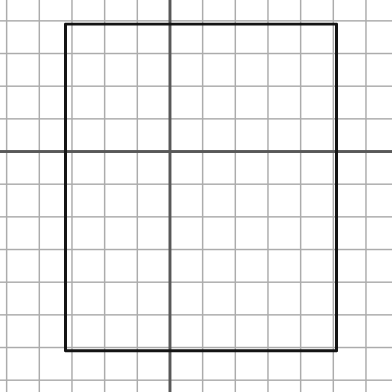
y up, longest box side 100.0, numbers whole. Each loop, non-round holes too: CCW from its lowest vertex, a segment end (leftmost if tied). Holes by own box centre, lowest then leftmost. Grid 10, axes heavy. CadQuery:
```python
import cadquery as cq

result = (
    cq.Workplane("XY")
    .moveTo(-32.0, -61.0)
    .lineTo(51.0, -61.0)
    .lineTo(51.0, 39.0)
    .lineTo(-32.0, 39.0)
    .close()
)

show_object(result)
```